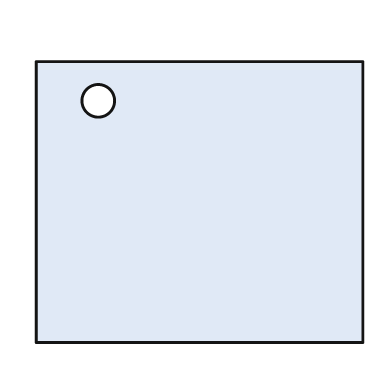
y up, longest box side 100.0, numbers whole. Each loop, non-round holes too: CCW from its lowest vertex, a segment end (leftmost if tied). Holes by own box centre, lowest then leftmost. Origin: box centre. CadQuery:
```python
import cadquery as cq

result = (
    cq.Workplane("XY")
    .moveTo(-50.0, -43.0)
    .lineTo(50.0, -43.0)
    .lineTo(50.0, 43.0)
    .lineTo(-50.0, 43.0)
    .close()
    .moveTo(-31.0, 31.0)
    .circle(5.0)
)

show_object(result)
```